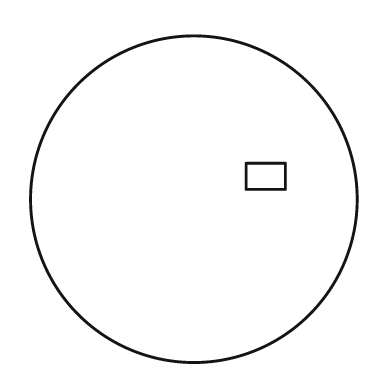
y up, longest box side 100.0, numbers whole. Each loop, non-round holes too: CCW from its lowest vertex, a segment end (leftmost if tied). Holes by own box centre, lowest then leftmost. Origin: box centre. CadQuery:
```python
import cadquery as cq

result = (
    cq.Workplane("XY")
    .moveTo(0.0, 0.0)
    .circle(50.0)
    .moveTo(16.0, 3.0)
    .lineTo(28.0, 3.0)
    .lineTo(28.0, 11.0)
    .lineTo(16.0, 11.0)
    .close()
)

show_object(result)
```